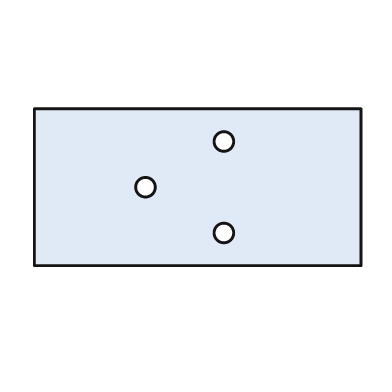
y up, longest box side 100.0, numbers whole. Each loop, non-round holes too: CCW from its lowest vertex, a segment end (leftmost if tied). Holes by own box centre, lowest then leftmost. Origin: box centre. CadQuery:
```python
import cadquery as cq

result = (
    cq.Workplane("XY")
    .moveTo(-50.0, -24.0)
    .lineTo(50.0, -24.0)
    .lineTo(50.0, 24.0)
    .lineTo(-50.0, 24.0)
    .close()
    .moveTo(8.0, -14.0)
    .circle(3.0)
    .moveTo(-16.0, 0.0)
    .circle(3.0)
    .moveTo(8.0, 14.0)
    .circle(3.0)
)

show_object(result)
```